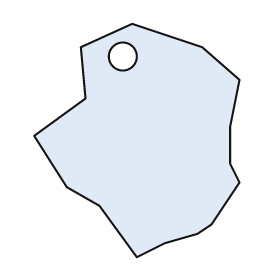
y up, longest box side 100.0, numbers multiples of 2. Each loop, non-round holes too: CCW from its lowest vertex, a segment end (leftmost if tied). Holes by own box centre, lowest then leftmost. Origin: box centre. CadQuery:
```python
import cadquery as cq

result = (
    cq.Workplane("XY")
    .moveTo(0.0, -50.0)
    .lineTo(12.0, -44.0)
    .lineTo(26.0, -40.0)
    .lineTo(32.0, -36.0)
    .lineTo(44.0, -18.0)
    .lineTo(40.0, -10.0)
    .lineTo(40.0, 6.0)
    .lineTo(44.0, 26.0)
    .lineTo(28.0, 40.0)
    .lineTo(-2.0, 50.0)
    .lineTo(-24.0, 40.0)
    .lineTo(-22.0, 18.0)
    .lineTo(-44.0, 2.0)
    .lineTo(-30.0, -20.0)
    .lineTo(-16.0, -28.0)
    .close()
    .moveTo(-6.0, 36.0)
    .circle(6.0)
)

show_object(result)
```